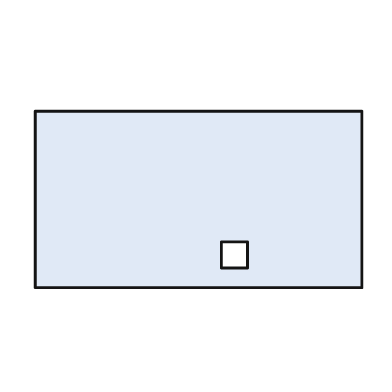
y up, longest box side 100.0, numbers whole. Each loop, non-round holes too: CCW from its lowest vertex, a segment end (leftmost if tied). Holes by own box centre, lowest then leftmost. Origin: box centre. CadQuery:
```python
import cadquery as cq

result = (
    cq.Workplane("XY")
    .moveTo(-50.0, -27.0)
    .lineTo(50.0, -27.0)
    .lineTo(50.0, 27.0)
    .lineTo(-50.0, 27.0)
    .close()
    .moveTo(7.0, -21.0)
    .lineTo(15.0, -21.0)
    .lineTo(15.0, -13.0)
    .lineTo(7.0, -13.0)
    .close()
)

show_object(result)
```